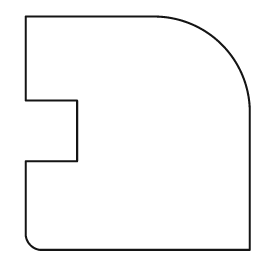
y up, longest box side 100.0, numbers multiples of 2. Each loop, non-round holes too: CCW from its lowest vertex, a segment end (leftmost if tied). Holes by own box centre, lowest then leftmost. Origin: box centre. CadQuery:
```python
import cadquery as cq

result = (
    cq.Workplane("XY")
    .moveTo(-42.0, -50.0)
    .lineTo(48.0, -50.0)
    .lineTo(48.0, 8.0)
    .threePointArc((36.0, 38.0), (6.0, 50.0))
    .lineTo(-48.0, 50.0)
    .lineTo(-48.0, 14.0)
    .lineTo(-26.0, 14.0)
    .lineTo(-26.0, -12.0)
    .lineTo(-48.0, -12.0)
    .lineTo(-48.0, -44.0)
    .threePointArc((-46.0, -48.0), (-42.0, -50.0))
    .close()
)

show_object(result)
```